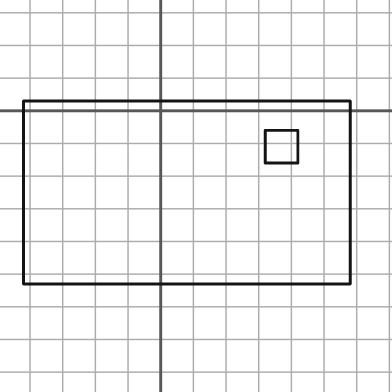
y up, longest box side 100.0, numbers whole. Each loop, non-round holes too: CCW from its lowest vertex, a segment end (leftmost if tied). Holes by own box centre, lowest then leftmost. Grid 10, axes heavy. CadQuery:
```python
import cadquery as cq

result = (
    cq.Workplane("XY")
    .moveTo(-42.0, -53.0)
    .lineTo(58.0, -53.0)
    .lineTo(58.0, 3.0)
    .lineTo(-42.0, 3.0)
    .close()
    .moveTo(32.0, -16.0)
    .lineTo(42.0, -16.0)
    .lineTo(42.0, -6.0)
    .lineTo(32.0, -6.0)
    .close()
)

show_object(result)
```